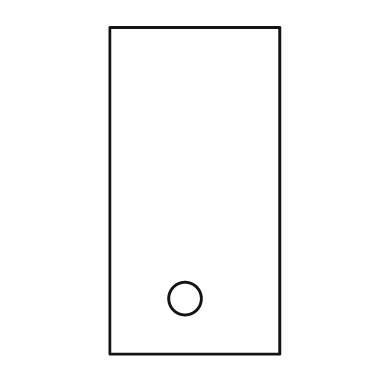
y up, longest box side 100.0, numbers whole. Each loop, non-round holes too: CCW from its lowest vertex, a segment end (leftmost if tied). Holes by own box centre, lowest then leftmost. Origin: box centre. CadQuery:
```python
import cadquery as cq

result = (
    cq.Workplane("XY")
    .moveTo(-26.0, -50.0)
    .lineTo(26.0, -50.0)
    .lineTo(26.0, 50.0)
    .lineTo(-26.0, 50.0)
    .close()
    .moveTo(-3.0, -33.0)
    .circle(5.0)
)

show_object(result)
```